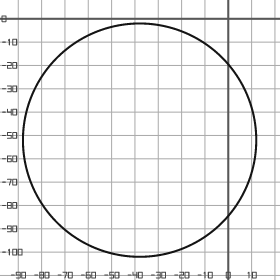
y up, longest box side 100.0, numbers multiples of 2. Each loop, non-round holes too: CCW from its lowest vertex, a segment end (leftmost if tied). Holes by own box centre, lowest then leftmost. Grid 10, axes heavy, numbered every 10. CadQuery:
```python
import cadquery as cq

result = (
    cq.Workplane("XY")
    .moveTo(-38.0, -52.0)
    .circle(50.0)
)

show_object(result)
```